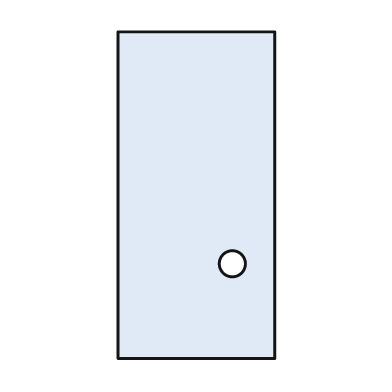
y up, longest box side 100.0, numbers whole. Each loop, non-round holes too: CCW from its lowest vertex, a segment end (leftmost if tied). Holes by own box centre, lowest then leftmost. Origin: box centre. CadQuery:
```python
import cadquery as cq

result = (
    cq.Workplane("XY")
    .moveTo(-24.0, -50.0)
    .lineTo(24.0, -50.0)
    .lineTo(24.0, 50.0)
    .lineTo(-24.0, 50.0)
    .close()
    .moveTo(11.0, -21.0)
    .circle(4.0)
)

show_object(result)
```